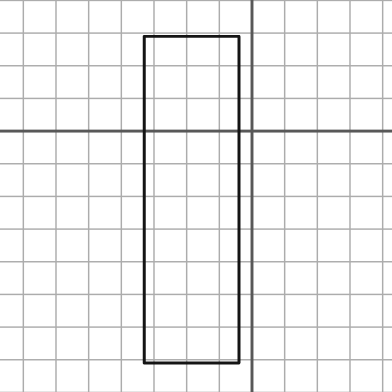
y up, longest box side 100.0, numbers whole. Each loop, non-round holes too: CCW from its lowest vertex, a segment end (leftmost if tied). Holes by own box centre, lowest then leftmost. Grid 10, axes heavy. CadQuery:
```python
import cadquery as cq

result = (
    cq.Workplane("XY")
    .moveTo(-33.0, -71.0)
    .lineTo(-4.0, -71.0)
    .lineTo(-4.0, 29.0)
    .lineTo(-33.0, 29.0)
    .close()
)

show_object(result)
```